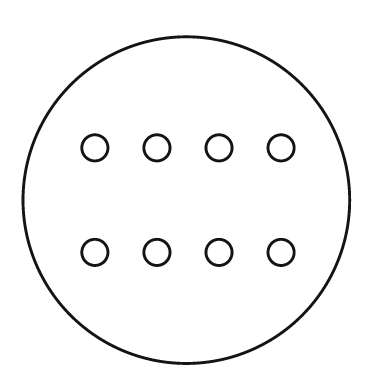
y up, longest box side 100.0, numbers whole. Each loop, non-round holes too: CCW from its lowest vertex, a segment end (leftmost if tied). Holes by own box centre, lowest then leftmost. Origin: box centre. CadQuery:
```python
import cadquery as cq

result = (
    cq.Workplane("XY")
    .moveTo(0.0, 0.0)
    .circle(50.0)
    .moveTo(-28.0, -16.0)
    .circle(4.0)
    .moveTo(-9.0, -16.0)
    .circle(4.0)
    .moveTo(10.0, -16.0)
    .circle(4.0)
    .moveTo(29.0, -16.0)
    .circle(4.0)
    .moveTo(-28.0, 16.0)
    .circle(4.0)
    .moveTo(-9.0, 16.0)
    .circle(4.0)
    .moveTo(10.0, 16.0)
    .circle(4.0)
    .moveTo(29.0, 16.0)
    .circle(4.0)
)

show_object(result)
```